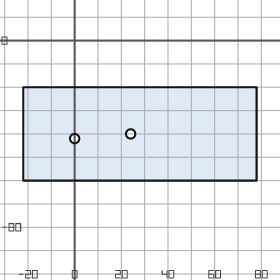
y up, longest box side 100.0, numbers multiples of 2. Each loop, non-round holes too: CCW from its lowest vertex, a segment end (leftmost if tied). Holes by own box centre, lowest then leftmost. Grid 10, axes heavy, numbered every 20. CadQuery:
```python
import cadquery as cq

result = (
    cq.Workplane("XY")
    .moveTo(-22.0, -60.0)
    .lineTo(78.0, -60.0)
    .lineTo(78.0, -20.0)
    .lineTo(-22.0, -20.0)
    .close()
    .moveTo(0.0, -42.0)
    .circle(2.0)
    .moveTo(24.0, -40.0)
    .circle(2.0)
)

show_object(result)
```